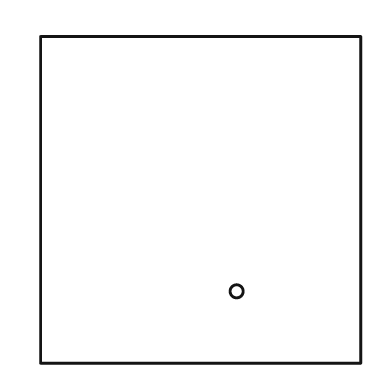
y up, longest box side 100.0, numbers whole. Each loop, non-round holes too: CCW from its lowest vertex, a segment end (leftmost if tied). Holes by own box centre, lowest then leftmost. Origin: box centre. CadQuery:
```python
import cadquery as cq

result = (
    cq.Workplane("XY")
    .moveTo(-49.0, -50.0)
    .lineTo(49.0, -50.0)
    .lineTo(49.0, 50.0)
    .lineTo(-49.0, 50.0)
    .close()
    .moveTo(11.0, -28.0)
    .circle(2.0)
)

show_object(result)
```